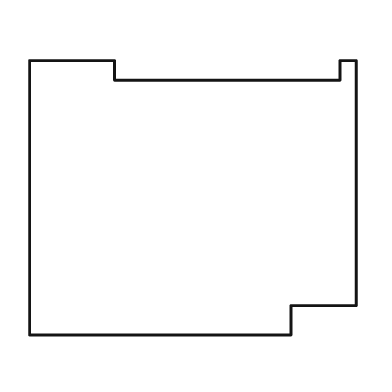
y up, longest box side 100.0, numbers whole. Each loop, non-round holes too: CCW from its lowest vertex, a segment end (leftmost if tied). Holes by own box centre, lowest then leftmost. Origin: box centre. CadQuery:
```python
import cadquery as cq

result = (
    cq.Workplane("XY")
    .moveTo(-50.0, -42.0)
    .lineTo(30.0, -42.0)
    .lineTo(30.0, -33.0)
    .lineTo(50.0, -33.0)
    .lineTo(50.0, 42.0)
    .lineTo(45.0, 42.0)
    .lineTo(45.0, 36.0)
    .lineTo(-24.0, 36.0)
    .lineTo(-24.0, 42.0)
    .lineTo(-50.0, 42.0)
    .close()
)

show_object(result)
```